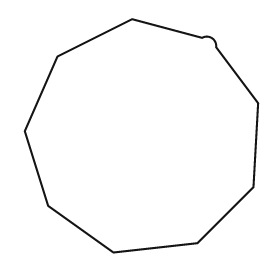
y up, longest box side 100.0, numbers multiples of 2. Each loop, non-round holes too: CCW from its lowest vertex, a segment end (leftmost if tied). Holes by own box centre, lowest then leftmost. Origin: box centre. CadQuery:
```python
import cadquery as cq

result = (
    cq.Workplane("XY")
    .moveTo(-12.0, -50.0)
    .lineTo(24.0, -46.0)
    .lineTo(48.0, -22.0)
    .lineTo(50.0, 14.0)
    .lineTo(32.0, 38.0)
    .threePointArc((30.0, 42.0), (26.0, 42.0))
    .lineTo(-4.0, 50.0)
    .lineTo(-36.0, 34.0)
    .lineTo(-50.0, 2.0)
    .lineTo(-40.0, -30.0)
    .close()
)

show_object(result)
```